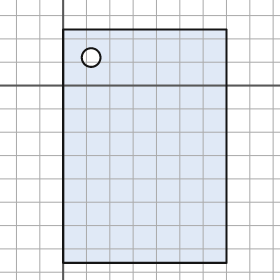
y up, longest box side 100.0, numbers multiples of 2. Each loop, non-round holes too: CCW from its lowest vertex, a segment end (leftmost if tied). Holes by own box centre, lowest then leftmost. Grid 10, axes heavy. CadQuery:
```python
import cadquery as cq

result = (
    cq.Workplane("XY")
    .moveTo(0.0, -76.0)
    .lineTo(70.0, -76.0)
    .lineTo(70.0, 24.0)
    .lineTo(0.0, 24.0)
    .close()
    .moveTo(12.0, 12.0)
    .circle(4.0)
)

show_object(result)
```